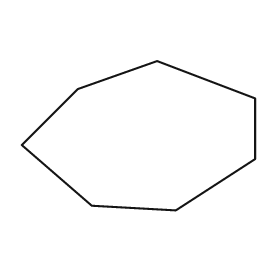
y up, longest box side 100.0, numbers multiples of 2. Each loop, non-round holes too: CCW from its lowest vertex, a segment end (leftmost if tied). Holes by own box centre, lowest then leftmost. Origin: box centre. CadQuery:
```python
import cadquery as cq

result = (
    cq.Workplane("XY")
    .moveTo(16.0, -32.0)
    .lineTo(50.0, -10.0)
    .lineTo(50.0, 16.0)
    .lineTo(8.0, 32.0)
    .lineTo(-26.0, 20.0)
    .lineTo(-50.0, -4.0)
    .lineTo(-20.0, -30.0)
    .close()
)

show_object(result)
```